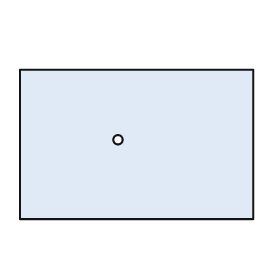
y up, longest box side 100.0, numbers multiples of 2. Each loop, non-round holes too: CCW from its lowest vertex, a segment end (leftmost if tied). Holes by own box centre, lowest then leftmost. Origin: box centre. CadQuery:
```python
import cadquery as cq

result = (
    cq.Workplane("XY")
    .moveTo(-50.0, -32.0)
    .lineTo(50.0, -32.0)
    .lineTo(50.0, 32.0)
    .lineTo(-50.0, 32.0)
    .close()
    .moveTo(-8.0, 2.0)
    .circle(2.0)
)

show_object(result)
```